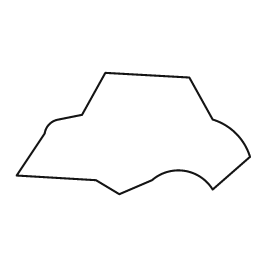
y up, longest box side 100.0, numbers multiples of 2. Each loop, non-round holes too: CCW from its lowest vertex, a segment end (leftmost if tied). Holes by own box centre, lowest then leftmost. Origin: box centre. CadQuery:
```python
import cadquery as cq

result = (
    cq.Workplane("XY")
    .moveTo(-6.0, -26.0)
    .lineTo(8.0, -20.0)
    .threePointArc((22.0, -16.0), (34.0, -24.0))
    .lineTo(50.0, -10.0)
    .threePointArc((44.0, 0.0), (34.0, 6.0))
    .lineTo(24.0, 24.0)
    .lineTo(-12.0, 26.0)
    .lineTo(-22.0, 8.0)
    .lineTo(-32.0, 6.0)
    .threePointArc((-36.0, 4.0), (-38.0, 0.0))
    .lineTo(-50.0, -18.0)
    .lineTo(-16.0, -20.0)
    .close()
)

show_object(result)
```